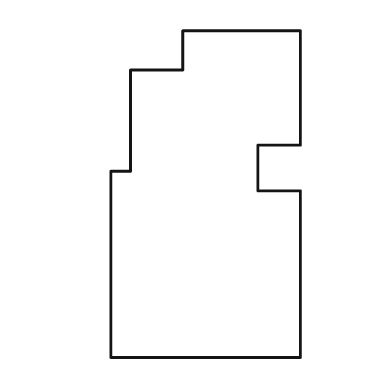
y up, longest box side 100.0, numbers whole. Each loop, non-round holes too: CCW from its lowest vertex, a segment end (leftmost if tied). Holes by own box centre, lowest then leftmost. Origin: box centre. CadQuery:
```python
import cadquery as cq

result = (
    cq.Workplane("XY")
    .moveTo(-29.0, -50.0)
    .lineTo(29.0, -50.0)
    .lineTo(29.0, 1.0)
    .lineTo(16.0, 1.0)
    .lineTo(16.0, 15.0)
    .lineTo(29.0, 15.0)
    .lineTo(29.0, 50.0)
    .lineTo(-7.0, 50.0)
    .lineTo(-7.0, 38.0)
    .lineTo(-23.0, 38.0)
    .lineTo(-23.0, 7.0)
    .lineTo(-29.0, 7.0)
    .close()
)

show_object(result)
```